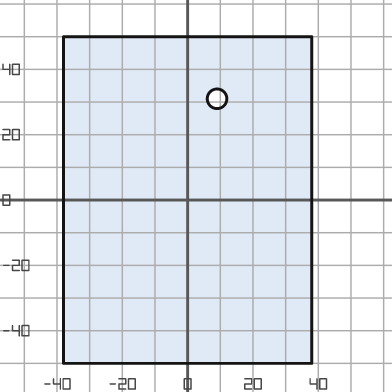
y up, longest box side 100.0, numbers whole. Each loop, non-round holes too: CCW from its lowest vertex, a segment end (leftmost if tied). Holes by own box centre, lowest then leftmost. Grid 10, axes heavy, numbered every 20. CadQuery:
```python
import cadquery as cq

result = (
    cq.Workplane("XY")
    .moveTo(-38.0, -50.0)
    .lineTo(38.0, -50.0)
    .lineTo(38.0, 50.0)
    .lineTo(-38.0, 50.0)
    .close()
    .moveTo(9.0, 31.0)
    .circle(3.0)
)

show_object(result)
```